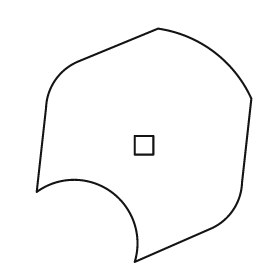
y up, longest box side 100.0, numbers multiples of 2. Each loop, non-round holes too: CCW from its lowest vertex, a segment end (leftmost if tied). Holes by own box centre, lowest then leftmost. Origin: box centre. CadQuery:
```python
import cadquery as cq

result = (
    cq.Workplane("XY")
    .moveTo(-4.0, -50.0)
    .lineTo(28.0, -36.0)
    .threePointArc((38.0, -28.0), (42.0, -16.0))
    .lineTo(46.0, 20.0)
    .threePointArc((30.0, 40.0), (6.0, 50.0))
    .lineTo(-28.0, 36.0)
    .threePointArc((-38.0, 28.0), (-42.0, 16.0))
    .lineTo(-46.0, -20.0)
    .threePointArc((-14.0, -20.0), (-4.0, -50.0))
    .close()
    .moveTo(-4.0, -4.0)
    .lineTo(4.0, -4.0)
    .lineTo(4.0, 4.0)
    .lineTo(-4.0, 4.0)
    .close()
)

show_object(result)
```